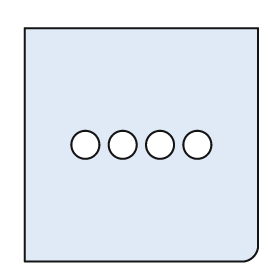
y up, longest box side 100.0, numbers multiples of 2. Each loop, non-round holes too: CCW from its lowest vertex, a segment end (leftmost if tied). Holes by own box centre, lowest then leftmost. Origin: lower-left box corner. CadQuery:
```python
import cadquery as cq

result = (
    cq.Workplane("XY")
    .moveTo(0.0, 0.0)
    .lineTo(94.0, 0.0)
    .threePointArc((98.0, 2.0), (100.0, 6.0))
    .lineTo(100.0, 100.0)
    .lineTo(0.0, 100.0)
    .close()
    .moveTo(26.0, 50.0)
    .circle(6.0)
    .moveTo(42.0, 50.0)
    .circle(6.0)
    .moveTo(58.0, 50.0)
    .circle(6.0)
    .moveTo(74.0, 50.0)
    .circle(6.0)
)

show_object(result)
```